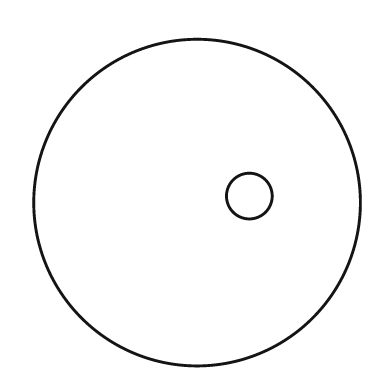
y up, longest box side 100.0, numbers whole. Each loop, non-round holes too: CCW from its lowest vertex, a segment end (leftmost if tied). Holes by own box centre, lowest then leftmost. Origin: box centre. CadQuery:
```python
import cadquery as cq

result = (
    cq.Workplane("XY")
    .moveTo(0.0, 0.0)
    .circle(50.0)
    .moveTo(16.0, 2.0)
    .circle(7.0)
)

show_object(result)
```